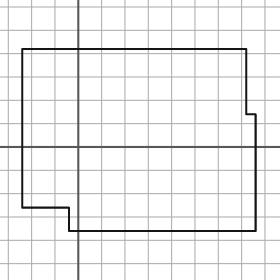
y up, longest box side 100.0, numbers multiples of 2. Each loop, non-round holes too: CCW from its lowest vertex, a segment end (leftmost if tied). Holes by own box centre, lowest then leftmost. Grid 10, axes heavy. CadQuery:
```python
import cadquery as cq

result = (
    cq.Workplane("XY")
    .moveTo(-4.0, -36.0)
    .lineTo(76.0, -36.0)
    .lineTo(76.0, 14.0)
    .lineTo(72.0, 14.0)
    .lineTo(72.0, 42.0)
    .lineTo(-24.0, 42.0)
    .lineTo(-24.0, -26.0)
    .lineTo(-4.0, -26.0)
    .close()
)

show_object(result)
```